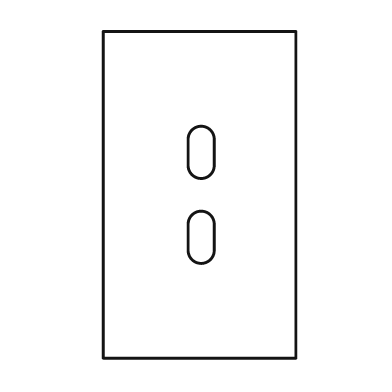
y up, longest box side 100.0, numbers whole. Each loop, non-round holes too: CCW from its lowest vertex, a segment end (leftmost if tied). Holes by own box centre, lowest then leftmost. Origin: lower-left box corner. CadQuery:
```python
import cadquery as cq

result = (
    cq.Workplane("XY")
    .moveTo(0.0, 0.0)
    .lineTo(59.0, 0.0)
    .lineTo(59.0, 100.0)
    .lineTo(0.0, 100.0)
    .close()
    .moveTo(26.0, 33.0)
    .threePointArc((30.0, 29.0), (34.0, 33.0))
    .lineTo(34.0, 41.0)
    .threePointArc((30.0, 45.0), (26.0, 41.0))
    .close()
    .moveTo(26.0, 59.0)
    .threePointArc((30.0, 55.0), (34.0, 59.0))
    .lineTo(34.0, 67.0)
    .threePointArc((30.0, 71.0), (26.0, 67.0))
    .close()
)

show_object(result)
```